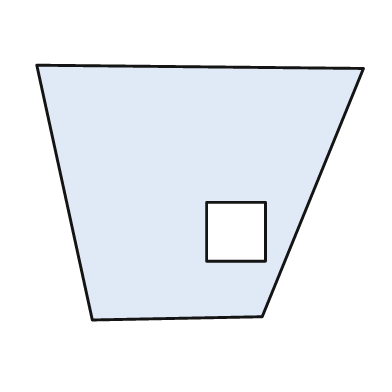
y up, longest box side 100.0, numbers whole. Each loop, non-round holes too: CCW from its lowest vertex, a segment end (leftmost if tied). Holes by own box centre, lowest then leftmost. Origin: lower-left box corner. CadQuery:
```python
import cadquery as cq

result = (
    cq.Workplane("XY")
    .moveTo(17.0, 0.0)
    .lineTo(69.0, 1.0)
    .lineTo(100.0, 77.0)
    .lineTo(0.0, 78.0)
    .close()
    .moveTo(52.0, 18.0)
    .lineTo(70.0, 18.0)
    .lineTo(70.0, 36.0)
    .lineTo(52.0, 36.0)
    .close()
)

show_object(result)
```